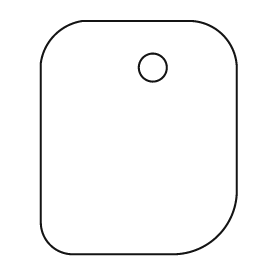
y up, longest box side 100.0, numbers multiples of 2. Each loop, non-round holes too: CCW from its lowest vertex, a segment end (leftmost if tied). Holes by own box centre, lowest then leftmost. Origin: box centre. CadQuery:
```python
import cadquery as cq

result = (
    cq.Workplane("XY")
    .moveTo(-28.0, -50.0)
    .lineTo(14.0, -50.0)
    .threePointArc((34.0, -42.0), (42.0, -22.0))
    .lineTo(42.0, 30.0)
    .threePointArc((36.0, 44.0), (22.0, 50.0))
    .lineTo(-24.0, 50.0)
    .threePointArc((-36.0, 44.0), (-42.0, 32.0))
    .lineTo(-42.0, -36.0)
    .threePointArc((-38.0, -46.0), (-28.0, -50.0))
    .close()
    .moveTo(6.0, 30.0)
    .circle(6.0)
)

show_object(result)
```